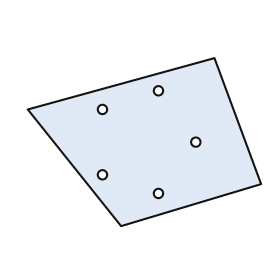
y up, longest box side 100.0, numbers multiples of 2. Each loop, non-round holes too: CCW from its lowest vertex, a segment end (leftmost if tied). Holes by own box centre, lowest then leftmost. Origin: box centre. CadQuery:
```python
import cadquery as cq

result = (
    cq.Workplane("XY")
    .moveTo(-10.0, -36.0)
    .lineTo(50.0, -18.0)
    .lineTo(30.0, 36.0)
    .lineTo(-50.0, 14.0)
    .close()
    .moveTo(6.0, -22.0)
    .circle(2.0)
    .moveTo(-18.0, -14.0)
    .circle(2.0)
    .moveTo(22.0, 0.0)
    .circle(2.0)
    .moveTo(-18.0, 14.0)
    .circle(2.0)
    .moveTo(6.0, 22.0)
    .circle(2.0)
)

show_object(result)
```